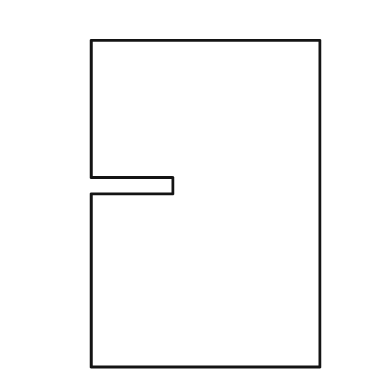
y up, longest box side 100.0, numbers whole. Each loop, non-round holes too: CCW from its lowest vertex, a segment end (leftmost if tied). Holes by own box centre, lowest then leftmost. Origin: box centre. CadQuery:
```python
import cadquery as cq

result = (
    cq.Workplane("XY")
    .moveTo(-35.0, -50.0)
    .lineTo(35.0, -50.0)
    .lineTo(35.0, 50.0)
    .lineTo(-35.0, 50.0)
    .lineTo(-35.0, 8.0)
    .lineTo(-10.0, 8.0)
    .lineTo(-10.0, 3.0)
    .lineTo(-35.0, 3.0)
    .close()
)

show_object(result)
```